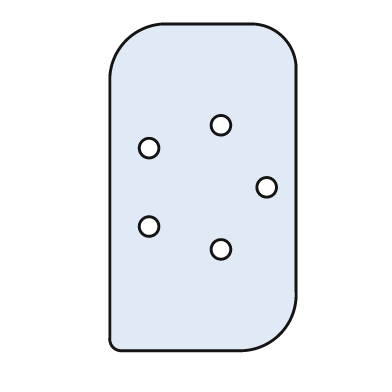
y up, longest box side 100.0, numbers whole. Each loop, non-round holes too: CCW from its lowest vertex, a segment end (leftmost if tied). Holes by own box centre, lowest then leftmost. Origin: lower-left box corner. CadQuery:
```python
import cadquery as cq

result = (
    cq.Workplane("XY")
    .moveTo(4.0, 0.0)
    .lineTo(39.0, 0.0)
    .threePointArc((52.0, 5.0), (57.0, 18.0))
    .lineTo(57.0, 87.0)
    .threePointArc((53.0, 96.0), (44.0, 100.0))
    .lineTo(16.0, 100.0)
    .threePointArc((5.0, 95.0), (0.0, 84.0))
    .lineTo(0.0, 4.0)
    .threePointArc((1.0, 1.0), (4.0, 0.0))
    .close()
    .moveTo(34.0, 31.0)
    .circle(3.0)
    .moveTo(12.0, 38.0)
    .circle(3.0)
    .moveTo(48.0, 50.0)
    .circle(3.0)
    .moveTo(12.0, 62.0)
    .circle(3.0)
    .moveTo(34.0, 69.0)
    .circle(3.0)
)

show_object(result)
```